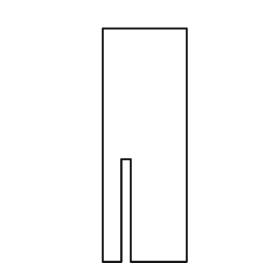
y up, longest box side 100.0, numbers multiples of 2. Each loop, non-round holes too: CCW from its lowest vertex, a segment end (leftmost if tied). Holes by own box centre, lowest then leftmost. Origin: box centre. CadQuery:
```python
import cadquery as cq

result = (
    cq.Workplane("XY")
    .moveTo(-18.0, -50.0)
    .lineTo(-10.0, -50.0)
    .lineTo(-10.0, -6.0)
    .lineTo(-6.0, -6.0)
    .lineTo(-6.0, -50.0)
    .lineTo(18.0, -50.0)
    .lineTo(18.0, 50.0)
    .lineTo(-18.0, 50.0)
    .close()
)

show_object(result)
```